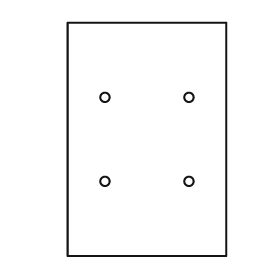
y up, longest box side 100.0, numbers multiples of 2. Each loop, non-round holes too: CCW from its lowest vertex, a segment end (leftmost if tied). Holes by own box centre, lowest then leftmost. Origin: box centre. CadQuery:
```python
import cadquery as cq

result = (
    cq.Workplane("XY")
    .moveTo(-34.0, -50.0)
    .lineTo(34.0, -50.0)
    .lineTo(34.0, 50.0)
    .lineTo(-34.0, 50.0)
    .close()
    .moveTo(-18.0, -18.0)
    .circle(2.0)
    .moveTo(18.0, -18.0)
    .circle(2.0)
    .moveTo(-18.0, 18.0)
    .circle(2.0)
    .moveTo(18.0, 18.0)
    .circle(2.0)
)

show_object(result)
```